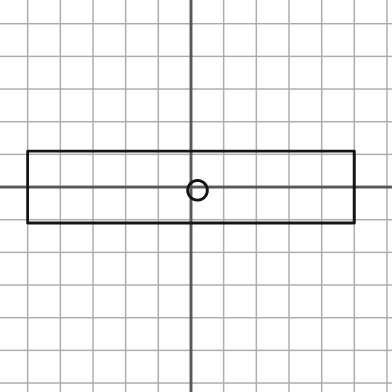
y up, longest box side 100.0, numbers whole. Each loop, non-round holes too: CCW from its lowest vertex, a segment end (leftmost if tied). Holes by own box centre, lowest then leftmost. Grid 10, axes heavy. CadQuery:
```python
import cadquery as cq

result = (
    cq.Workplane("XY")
    .moveTo(-50.0, -11.0)
    .lineTo(50.0, -11.0)
    .lineTo(50.0, 11.0)
    .lineTo(-50.0, 11.0)
    .close()
    .moveTo(2.0, -1.0)
    .circle(3.0)
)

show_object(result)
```